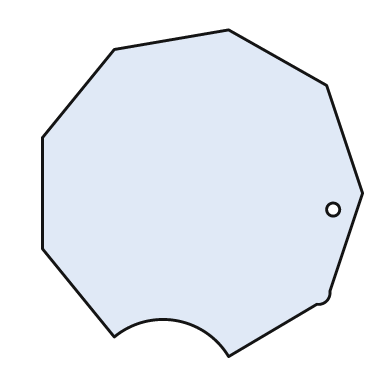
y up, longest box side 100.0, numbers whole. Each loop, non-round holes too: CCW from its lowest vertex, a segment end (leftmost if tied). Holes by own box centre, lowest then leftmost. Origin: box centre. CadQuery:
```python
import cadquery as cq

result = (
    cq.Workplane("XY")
    .moveTo(8.0, -50.0)
    .lineTo(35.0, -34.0)
    .threePointArc((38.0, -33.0), (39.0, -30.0))
    .lineTo(49.0, 0.0)
    .lineTo(38.0, 33.0)
    .lineTo(8.0, 50.0)
    .lineTo(-27.0, 44.0)
    .lineTo(-49.0, 17.0)
    .lineTo(-49.0, -17.0)
    .lineTo(-27.0, -44.0)
    .threePointArc((-8.0, -39.0), (8.0, -50.0))
    .close()
    .moveTo(40.0, -5.0)
    .circle(2.0)
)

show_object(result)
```